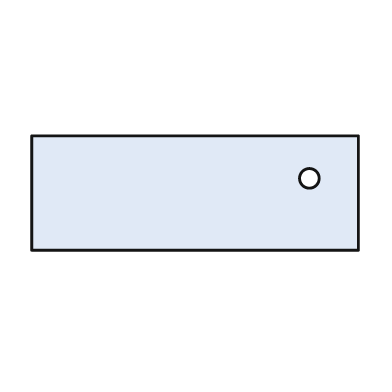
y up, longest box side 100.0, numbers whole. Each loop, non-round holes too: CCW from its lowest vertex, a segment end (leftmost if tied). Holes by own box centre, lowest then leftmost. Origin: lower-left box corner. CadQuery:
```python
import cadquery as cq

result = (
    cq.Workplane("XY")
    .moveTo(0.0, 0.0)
    .lineTo(100.0, 0.0)
    .lineTo(100.0, 35.0)
    .lineTo(0.0, 35.0)
    .close()
    .moveTo(85.0, 22.0)
    .circle(3.0)
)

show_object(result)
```